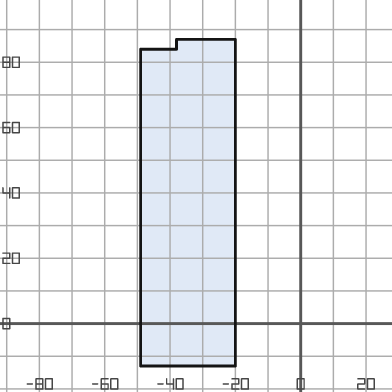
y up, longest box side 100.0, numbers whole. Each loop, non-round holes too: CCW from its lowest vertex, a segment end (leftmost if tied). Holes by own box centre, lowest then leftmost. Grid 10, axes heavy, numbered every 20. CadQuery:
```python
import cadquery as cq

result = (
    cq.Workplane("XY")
    .moveTo(-49.0, -13.0)
    .lineTo(-20.0, -13.0)
    .lineTo(-20.0, 87.0)
    .lineTo(-38.0, 87.0)
    .lineTo(-38.0, 84.0)
    .lineTo(-49.0, 84.0)
    .close()
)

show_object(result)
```